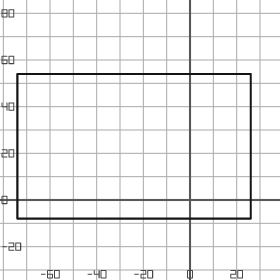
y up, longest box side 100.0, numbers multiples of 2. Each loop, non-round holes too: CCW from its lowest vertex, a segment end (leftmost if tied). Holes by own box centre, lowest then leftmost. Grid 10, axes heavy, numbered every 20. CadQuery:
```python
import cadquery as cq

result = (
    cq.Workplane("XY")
    .moveTo(-74.0, -8.0)
    .lineTo(26.0, -8.0)
    .lineTo(26.0, 54.0)
    .lineTo(-74.0, 54.0)
    .close()
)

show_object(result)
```